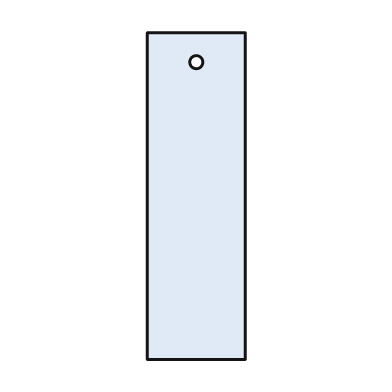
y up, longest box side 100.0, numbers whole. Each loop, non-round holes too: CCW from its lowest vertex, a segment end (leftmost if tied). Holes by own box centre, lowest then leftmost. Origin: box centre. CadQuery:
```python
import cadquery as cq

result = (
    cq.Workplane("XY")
    .moveTo(-15.0, -50.0)
    .lineTo(15.0, -50.0)
    .lineTo(15.0, 50.0)
    .lineTo(-15.0, 50.0)
    .close()
    .moveTo(0.0, 41.0)
    .circle(2.0)
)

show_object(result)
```